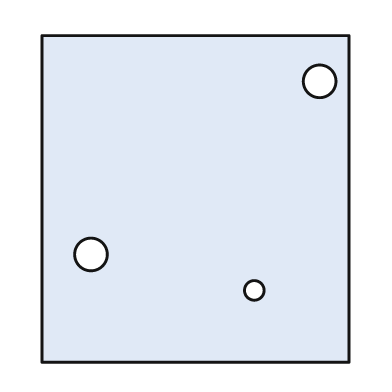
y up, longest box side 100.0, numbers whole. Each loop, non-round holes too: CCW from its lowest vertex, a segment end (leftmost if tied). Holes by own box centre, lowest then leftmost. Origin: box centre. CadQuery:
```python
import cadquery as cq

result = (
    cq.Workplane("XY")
    .moveTo(-47.0, -50.0)
    .lineTo(47.0, -50.0)
    .lineTo(47.0, 50.0)
    .lineTo(-47.0, 50.0)
    .close()
    .moveTo(18.0, -28.0)
    .circle(3.0)
    .moveTo(-32.0, -17.0)
    .circle(5.0)
    .moveTo(38.0, 36.0)
    .circle(5.0)
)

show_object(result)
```